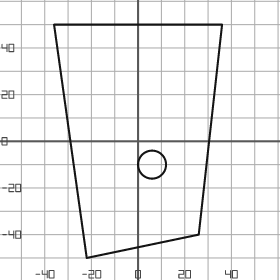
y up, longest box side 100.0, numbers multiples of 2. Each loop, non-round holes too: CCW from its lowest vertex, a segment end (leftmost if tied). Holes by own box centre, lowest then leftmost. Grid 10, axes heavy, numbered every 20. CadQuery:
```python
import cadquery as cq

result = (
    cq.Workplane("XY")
    .moveTo(-22.0, -50.0)
    .lineTo(26.0, -40.0)
    .lineTo(36.0, 50.0)
    .lineTo(-36.0, 50.0)
    .close()
    .moveTo(6.0, -10.0)
    .circle(6.0)
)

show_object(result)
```